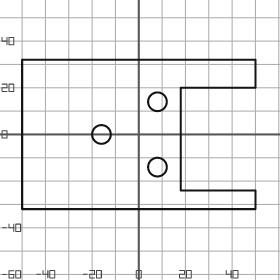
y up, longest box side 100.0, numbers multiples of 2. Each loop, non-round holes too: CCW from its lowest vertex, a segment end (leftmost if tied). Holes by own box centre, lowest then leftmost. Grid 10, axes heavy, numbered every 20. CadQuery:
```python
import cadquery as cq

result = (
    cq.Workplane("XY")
    .moveTo(-50.0, -32.0)
    .lineTo(50.0, -32.0)
    .lineTo(50.0, -24.0)
    .lineTo(18.0, -24.0)
    .lineTo(18.0, 20.0)
    .lineTo(50.0, 20.0)
    .lineTo(50.0, 32.0)
    .lineTo(-50.0, 32.0)
    .close()
    .moveTo(8.0, -14.0)
    .circle(4.0)
    .moveTo(-16.0, 0.0)
    .circle(4.0)
    .moveTo(8.0, 14.0)
    .circle(4.0)
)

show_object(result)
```